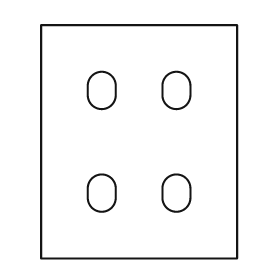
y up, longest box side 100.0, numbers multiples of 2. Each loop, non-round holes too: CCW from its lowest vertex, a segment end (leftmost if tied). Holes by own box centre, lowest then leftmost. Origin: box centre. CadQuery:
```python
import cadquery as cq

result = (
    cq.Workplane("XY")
    .moveTo(-42.0, -50.0)
    .lineTo(42.0, -50.0)
    .lineTo(42.0, 50.0)
    .lineTo(-42.0, 50.0)
    .close()
    .moveTo(-22.0, -24.0)
    .threePointArc((-16.0, -30.0), (-10.0, -24.0))
    .lineTo(-10.0, -20.0)
    .threePointArc((-16.0, -14.0), (-22.0, -20.0))
    .close()
    .moveTo(10.0, -24.0)
    .threePointArc((16.0, -30.0), (22.0, -24.0))
    .lineTo(22.0, -20.0)
    .threePointArc((16.0, -14.0), (10.0, -20.0))
    .close()
    .moveTo(-22.0, 20.0)
    .threePointArc((-16.0, 14.0), (-10.0, 20.0))
    .lineTo(-10.0, 24.0)
    .threePointArc((-16.0, 30.0), (-22.0, 24.0))
    .close()
    .moveTo(10.0, 20.0)
    .threePointArc((16.0, 14.0), (22.0, 20.0))
    .lineTo(22.0, 24.0)
    .threePointArc((16.0, 30.0), (10.0, 24.0))
    .close()
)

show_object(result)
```